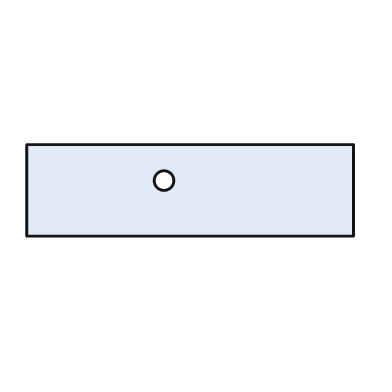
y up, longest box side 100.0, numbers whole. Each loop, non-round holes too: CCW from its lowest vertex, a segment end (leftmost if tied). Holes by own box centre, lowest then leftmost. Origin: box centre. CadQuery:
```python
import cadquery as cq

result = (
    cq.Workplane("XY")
    .moveTo(-50.0, -14.0)
    .lineTo(50.0, -14.0)
    .lineTo(50.0, 14.0)
    .lineTo(-50.0, 14.0)
    .close()
    .moveTo(-8.0, 3.0)
    .circle(3.0)
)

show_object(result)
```